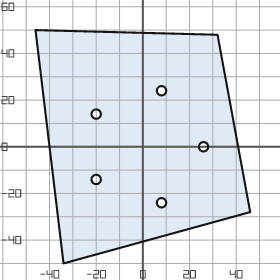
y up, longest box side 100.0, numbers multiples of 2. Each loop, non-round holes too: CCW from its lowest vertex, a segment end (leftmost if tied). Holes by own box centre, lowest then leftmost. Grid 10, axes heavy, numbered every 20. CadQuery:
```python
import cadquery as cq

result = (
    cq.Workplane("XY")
    .moveTo(-34.0, -50.0)
    .lineTo(46.0, -28.0)
    .lineTo(32.0, 48.0)
    .lineTo(-46.0, 50.0)
    .close()
    .moveTo(8.0, -24.0)
    .circle(2.0)
    .moveTo(-20.0, -14.0)
    .circle(2.0)
    .moveTo(26.0, 0.0)
    .circle(2.0)
    .moveTo(-20.0, 14.0)
    .circle(2.0)
    .moveTo(8.0, 24.0)
    .circle(2.0)
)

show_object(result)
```